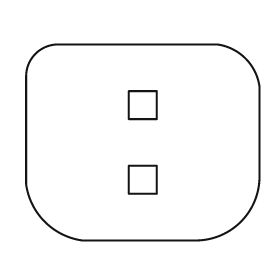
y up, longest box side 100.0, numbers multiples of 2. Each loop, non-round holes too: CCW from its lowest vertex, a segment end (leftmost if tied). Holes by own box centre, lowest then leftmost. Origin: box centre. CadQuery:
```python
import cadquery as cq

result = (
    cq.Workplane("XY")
    .moveTo(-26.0, -42.0)
    .lineTo(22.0, -42.0)
    .threePointArc((42.0, -34.0), (50.0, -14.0))
    .lineTo(50.0, 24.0)
    .threePointArc((44.0, 36.0), (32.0, 42.0))
    .lineTo(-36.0, 42.0)
    .threePointArc((-46.0, 38.0), (-50.0, 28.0))
    .lineTo(-50.0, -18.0)
    .threePointArc((-42.0, -34.0), (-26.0, -42.0))
    .close()
    .moveTo(-6.0, -22.0)
    .lineTo(6.0, -22.0)
    .lineTo(6.0, -10.0)
    .lineTo(-6.0, -10.0)
    .close()
    .moveTo(-6.0, 10.0)
    .lineTo(6.0, 10.0)
    .lineTo(6.0, 22.0)
    .lineTo(-6.0, 22.0)
    .close()
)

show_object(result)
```